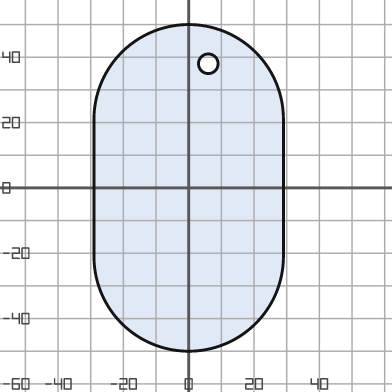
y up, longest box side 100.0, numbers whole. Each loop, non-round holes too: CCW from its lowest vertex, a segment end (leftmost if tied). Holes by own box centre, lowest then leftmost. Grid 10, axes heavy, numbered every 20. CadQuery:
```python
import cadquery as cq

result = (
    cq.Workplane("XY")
    .moveTo(-29.0, -21.0)
    .threePointArc((0.0, -50.0), (29.0, -21.0))
    .lineTo(29.0, 21.0)
    .threePointArc((0.0, 50.0), (-29.0, 21.0))
    .close()
    .moveTo(6.0, 38.0)
    .circle(3.0)
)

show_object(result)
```